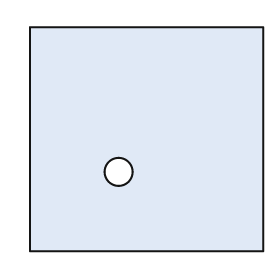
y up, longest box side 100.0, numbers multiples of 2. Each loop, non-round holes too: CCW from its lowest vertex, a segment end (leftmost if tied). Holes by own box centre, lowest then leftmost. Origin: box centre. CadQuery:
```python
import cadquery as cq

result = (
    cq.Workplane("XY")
    .moveTo(-50.0, -48.0)
    .lineTo(50.0, -48.0)
    .lineTo(50.0, 48.0)
    .lineTo(-50.0, 48.0)
    .close()
    .moveTo(-12.0, -14.0)
    .circle(6.0)
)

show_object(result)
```